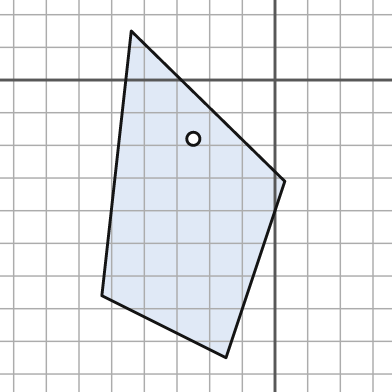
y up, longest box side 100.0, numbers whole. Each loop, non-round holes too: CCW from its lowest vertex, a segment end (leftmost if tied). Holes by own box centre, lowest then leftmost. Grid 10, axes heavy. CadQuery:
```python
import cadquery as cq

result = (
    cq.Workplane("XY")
    .moveTo(-15.0, -85.0)
    .lineTo(3.0, -31.0)
    .lineTo(-44.0, 15.0)
    .lineTo(-53.0, -66.0)
    .close()
    .moveTo(-25.0, -18.0)
    .circle(2.0)
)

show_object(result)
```